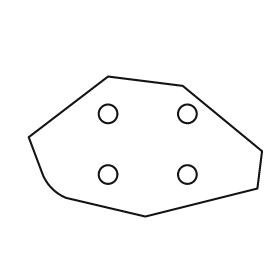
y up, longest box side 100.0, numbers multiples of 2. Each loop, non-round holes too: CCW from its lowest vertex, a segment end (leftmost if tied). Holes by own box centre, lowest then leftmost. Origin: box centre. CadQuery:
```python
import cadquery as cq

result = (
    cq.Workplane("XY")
    .moveTo(0.0, -30.0)
    .lineTo(48.0, -18.0)
    .lineTo(50.0, -2.0)
    .lineTo(16.0, 26.0)
    .lineTo(-16.0, 30.0)
    .lineTo(-50.0, 4.0)
    .lineTo(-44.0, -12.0)
    .threePointArc((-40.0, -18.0), (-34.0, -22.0))
    .close()
    .moveTo(-16.0, -12.0)
    .circle(4.0)
    .moveTo(18.0, -12.0)
    .circle(4.0)
    .moveTo(-16.0, 14.0)
    .circle(4.0)
    .moveTo(18.0, 14.0)
    .circle(4.0)
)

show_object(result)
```